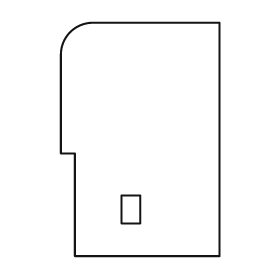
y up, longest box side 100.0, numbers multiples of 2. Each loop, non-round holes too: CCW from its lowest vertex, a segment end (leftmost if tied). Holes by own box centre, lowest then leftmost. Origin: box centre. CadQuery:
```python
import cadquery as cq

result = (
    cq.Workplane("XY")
    .moveTo(-28.0, -50.0)
    .lineTo(34.0, -50.0)
    .lineTo(34.0, 50.0)
    .lineTo(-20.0, 50.0)
    .threePointArc((-30.0, 46.0), (-34.0, 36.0))
    .lineTo(-34.0, -6.0)
    .lineTo(-28.0, -6.0)
    .close()
    .moveTo(-8.0, -36.0)
    .lineTo(0.0, -36.0)
    .lineTo(0.0, -24.0)
    .lineTo(-8.0, -24.0)
    .close()
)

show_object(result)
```